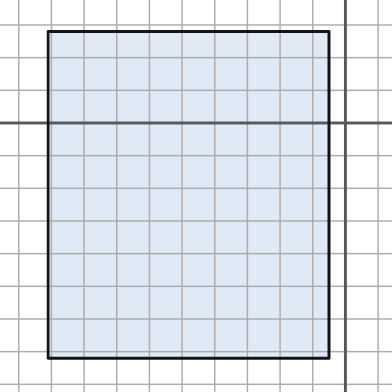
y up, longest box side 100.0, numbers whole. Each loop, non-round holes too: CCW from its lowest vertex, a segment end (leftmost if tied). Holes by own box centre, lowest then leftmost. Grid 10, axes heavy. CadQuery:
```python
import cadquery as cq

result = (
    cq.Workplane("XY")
    .moveTo(-91.0, -72.0)
    .lineTo(-5.0, -72.0)
    .lineTo(-5.0, 28.0)
    .lineTo(-91.0, 28.0)
    .close()
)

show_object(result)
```